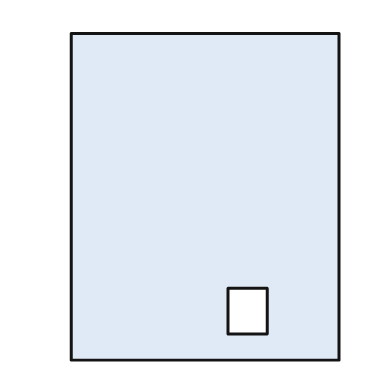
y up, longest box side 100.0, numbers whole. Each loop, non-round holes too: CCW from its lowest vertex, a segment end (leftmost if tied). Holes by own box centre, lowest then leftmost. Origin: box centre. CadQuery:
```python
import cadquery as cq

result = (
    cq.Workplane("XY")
    .moveTo(-41.0, -50.0)
    .lineTo(41.0, -50.0)
    .lineTo(41.0, 50.0)
    .lineTo(-41.0, 50.0)
    .close()
    .moveTo(7.0, -42.0)
    .lineTo(19.0, -42.0)
    .lineTo(19.0, -28.0)
    .lineTo(7.0, -28.0)
    .close()
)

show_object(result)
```